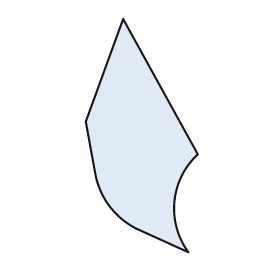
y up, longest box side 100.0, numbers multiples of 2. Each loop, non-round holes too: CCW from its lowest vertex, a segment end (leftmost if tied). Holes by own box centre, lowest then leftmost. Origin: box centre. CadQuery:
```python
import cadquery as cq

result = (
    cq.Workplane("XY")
    .moveTo(20.0, -50.0)
    .threePointArc((14.0, -28.0), (24.0, -8.0))
    .lineTo(-8.0, 50.0)
    .lineTo(-24.0, 6.0)
    .lineTo(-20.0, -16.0)
    .threePointArc((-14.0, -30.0), (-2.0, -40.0))
    .close()
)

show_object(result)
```